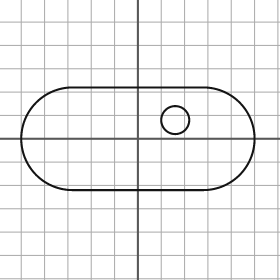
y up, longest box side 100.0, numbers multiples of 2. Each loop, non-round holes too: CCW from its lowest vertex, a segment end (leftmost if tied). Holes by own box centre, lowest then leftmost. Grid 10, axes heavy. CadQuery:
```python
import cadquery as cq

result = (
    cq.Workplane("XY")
    .moveTo(-28.0, -22.0)
    .lineTo(28.0, -22.0)
    .threePointArc((50.0, 0.0), (28.0, 22.0))
    .lineTo(-28.0, 22.0)
    .threePointArc((-50.0, 0.0), (-28.0, -22.0))
    .close()
    .moveTo(16.0, 8.0)
    .circle(6.0)
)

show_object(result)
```